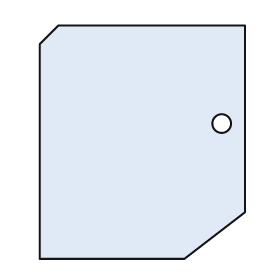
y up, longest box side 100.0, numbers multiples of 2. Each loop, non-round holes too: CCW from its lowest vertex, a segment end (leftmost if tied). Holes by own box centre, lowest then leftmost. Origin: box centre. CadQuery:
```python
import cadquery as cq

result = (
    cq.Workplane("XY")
    .moveTo(-44.0, -50.0)
    .lineTo(18.0, -50.0)
    .lineTo(44.0, -30.0)
    .lineTo(44.0, 50.0)
    .lineTo(-36.0, 50.0)
    .lineTo(-44.0, 42.0)
    .close()
    .moveTo(34.0, 8.0)
    .circle(4.0)
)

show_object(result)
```